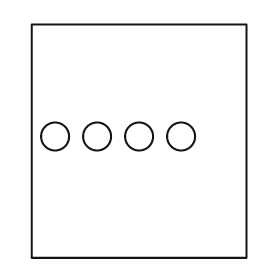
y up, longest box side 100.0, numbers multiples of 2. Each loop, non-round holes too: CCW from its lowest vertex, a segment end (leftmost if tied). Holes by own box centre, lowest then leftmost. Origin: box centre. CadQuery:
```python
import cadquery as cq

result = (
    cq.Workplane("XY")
    .moveTo(-46.0, -50.0)
    .lineTo(46.0, -50.0)
    .lineTo(46.0, 50.0)
    .lineTo(-46.0, 50.0)
    .close()
    .moveTo(-36.0, 2.0)
    .circle(6.0)
    .moveTo(-18.0, 2.0)
    .circle(6.0)
    .moveTo(0.0, 2.0)
    .circle(6.0)
    .moveTo(18.0, 2.0)
    .circle(6.0)
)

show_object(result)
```